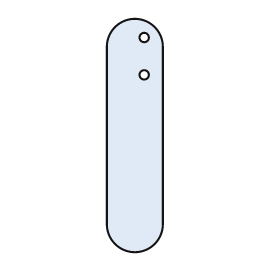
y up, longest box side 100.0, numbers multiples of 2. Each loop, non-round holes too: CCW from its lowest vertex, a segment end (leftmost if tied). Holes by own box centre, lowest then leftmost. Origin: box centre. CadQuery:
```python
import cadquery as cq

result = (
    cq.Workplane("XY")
    .moveTo(-12.0, -38.0)
    .threePointArc((0.0, -50.0), (12.0, -38.0))
    .lineTo(12.0, 38.0)
    .threePointArc((0.0, 50.0), (-12.0, 38.0))
    .close()
    .moveTo(4.0, 26.0)
    .circle(2.0)
    .moveTo(4.0, 42.0)
    .circle(2.0)
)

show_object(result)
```